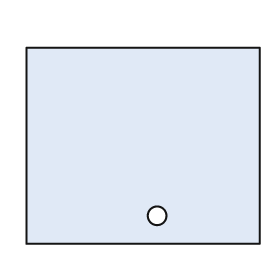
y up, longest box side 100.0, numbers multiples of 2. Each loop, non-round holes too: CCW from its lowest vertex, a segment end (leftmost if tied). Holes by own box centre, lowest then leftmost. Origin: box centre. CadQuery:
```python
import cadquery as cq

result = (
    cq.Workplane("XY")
    .moveTo(-50.0, -42.0)
    .lineTo(50.0, -42.0)
    .lineTo(50.0, 42.0)
    .lineTo(-50.0, 42.0)
    .close()
    .moveTo(6.0, -30.0)
    .circle(4.0)
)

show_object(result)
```